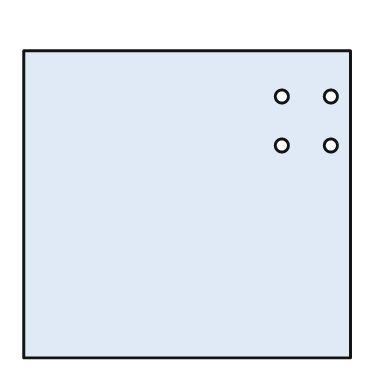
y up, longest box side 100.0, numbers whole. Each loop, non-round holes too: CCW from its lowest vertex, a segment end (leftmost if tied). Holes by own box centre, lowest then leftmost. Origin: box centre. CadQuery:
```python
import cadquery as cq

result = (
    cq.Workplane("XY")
    .moveTo(-50.0, -47.0)
    .lineTo(50.0, -47.0)
    .lineTo(50.0, 47.0)
    .lineTo(-50.0, 47.0)
    .close()
    .moveTo(29.0, 18.0)
    .circle(2.0)
    .moveTo(44.0, 18.0)
    .circle(2.0)
    .moveTo(29.0, 33.0)
    .circle(2.0)
    .moveTo(44.0, 33.0)
    .circle(2.0)
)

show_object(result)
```